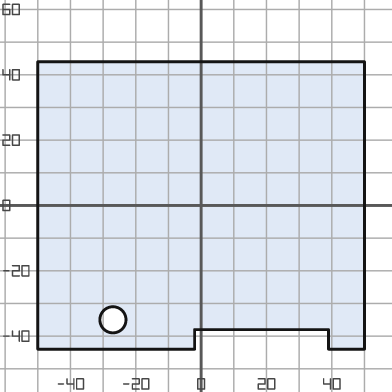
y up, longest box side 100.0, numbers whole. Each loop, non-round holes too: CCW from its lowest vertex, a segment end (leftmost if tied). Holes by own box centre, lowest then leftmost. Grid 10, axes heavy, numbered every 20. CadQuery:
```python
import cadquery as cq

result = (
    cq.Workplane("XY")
    .moveTo(-50.0, -44.0)
    .lineTo(-2.0, -44.0)
    .lineTo(-2.0, -38.0)
    .lineTo(39.0, -38.0)
    .lineTo(39.0, -44.0)
    .lineTo(50.0, -44.0)
    .lineTo(50.0, 44.0)
    .lineTo(-50.0, 44.0)
    .close()
    .moveTo(-27.0, -35.0)
    .circle(4.0)
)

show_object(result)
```